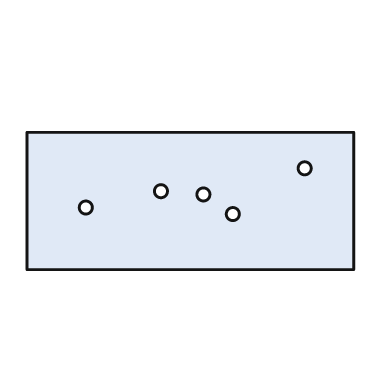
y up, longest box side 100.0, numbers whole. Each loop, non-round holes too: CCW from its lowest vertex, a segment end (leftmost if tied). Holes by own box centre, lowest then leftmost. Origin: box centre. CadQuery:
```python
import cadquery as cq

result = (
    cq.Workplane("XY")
    .moveTo(-50.0, -21.0)
    .lineTo(50.0, -21.0)
    .lineTo(50.0, 21.0)
    .lineTo(-50.0, 21.0)
    .close()
    .moveTo(13.0, -4.0)
    .circle(2.0)
    .moveTo(-32.0, -2.0)
    .circle(2.0)
    .moveTo(4.0, 2.0)
    .circle(2.0)
    .moveTo(-9.0, 3.0)
    .circle(2.0)
    .moveTo(35.0, 10.0)
    .circle(2.0)
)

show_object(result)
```